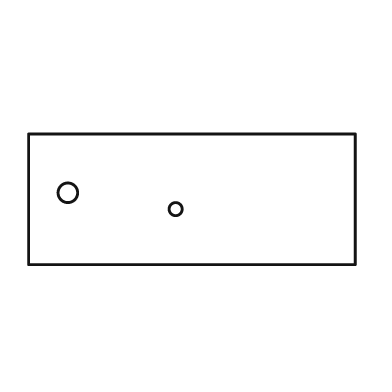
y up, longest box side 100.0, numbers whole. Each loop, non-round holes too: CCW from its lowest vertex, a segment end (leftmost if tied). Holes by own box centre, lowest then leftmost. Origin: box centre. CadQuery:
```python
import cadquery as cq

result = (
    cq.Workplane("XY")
    .moveTo(-50.0, -20.0)
    .lineTo(50.0, -20.0)
    .lineTo(50.0, 20.0)
    .lineTo(-50.0, 20.0)
    .close()
    .moveTo(-5.0, -3.0)
    .circle(2.0)
    .moveTo(-38.0, 2.0)
    .circle(3.0)
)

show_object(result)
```